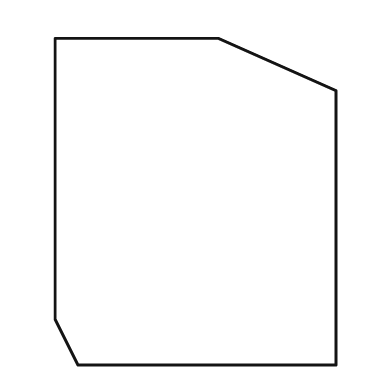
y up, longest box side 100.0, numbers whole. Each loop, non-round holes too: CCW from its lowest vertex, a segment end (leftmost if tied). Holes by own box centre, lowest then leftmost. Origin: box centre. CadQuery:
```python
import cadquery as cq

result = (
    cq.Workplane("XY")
    .moveTo(-36.0, -50.0)
    .lineTo(43.0, -50.0)
    .lineTo(43.0, 34.0)
    .lineTo(7.0, 50.0)
    .lineTo(-43.0, 50.0)
    .lineTo(-43.0, -36.0)
    .close()
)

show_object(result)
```